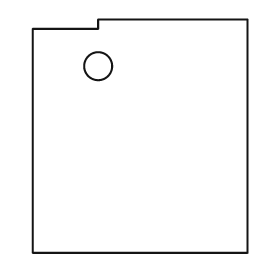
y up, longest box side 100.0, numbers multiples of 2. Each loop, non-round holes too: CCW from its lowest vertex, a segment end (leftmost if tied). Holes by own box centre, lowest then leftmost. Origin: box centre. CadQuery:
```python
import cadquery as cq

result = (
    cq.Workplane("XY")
    .moveTo(-46.0, -50.0)
    .lineTo(46.0, -50.0)
    .lineTo(46.0, 50.0)
    .lineTo(-18.0, 50.0)
    .lineTo(-18.0, 46.0)
    .lineTo(-46.0, 46.0)
    .close()
    .moveTo(-18.0, 30.0)
    .circle(6.0)
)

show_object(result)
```